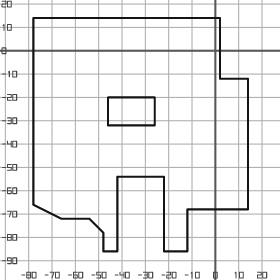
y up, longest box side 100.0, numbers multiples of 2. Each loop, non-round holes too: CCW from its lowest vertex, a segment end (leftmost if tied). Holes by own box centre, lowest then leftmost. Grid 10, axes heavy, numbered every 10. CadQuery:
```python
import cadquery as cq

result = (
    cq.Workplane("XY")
    .moveTo(-48.0, -86.0)
    .lineTo(-42.0, -86.0)
    .lineTo(-42.0, -54.0)
    .lineTo(-22.0, -54.0)
    .lineTo(-22.0, -86.0)
    .lineTo(-12.0, -86.0)
    .lineTo(-12.0, -68.0)
    .lineTo(14.0, -68.0)
    .lineTo(14.0, -12.0)
    .lineTo(2.0, -12.0)
    .lineTo(2.0, 14.0)
    .lineTo(-78.0, 14.0)
    .lineTo(-78.0, -66.0)
    .lineTo(-66.0, -72.0)
    .lineTo(-54.0, -72.0)
    .lineTo(-48.0, -78.0)
    .close()
    .moveTo(-46.0, -32.0)
    .lineTo(-26.0, -32.0)
    .lineTo(-26.0, -20.0)
    .lineTo(-46.0, -20.0)
    .close()
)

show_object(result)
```